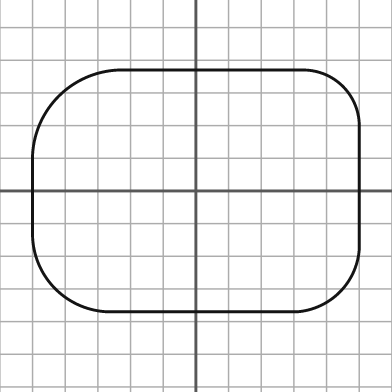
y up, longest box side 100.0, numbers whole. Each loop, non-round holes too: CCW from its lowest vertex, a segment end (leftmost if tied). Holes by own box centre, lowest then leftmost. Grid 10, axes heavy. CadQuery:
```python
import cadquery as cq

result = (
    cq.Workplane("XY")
    .moveTo(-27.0, -37.0)
    .lineTo(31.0, -37.0)
    .threePointArc((44.0, -31.0), (50.0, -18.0))
    .lineTo(50.0, 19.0)
    .threePointArc((45.0, 32.0), (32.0, 37.0))
    .lineTo(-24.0, 37.0)
    .threePointArc((-42.0, 29.0), (-50.0, 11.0))
    .lineTo(-50.0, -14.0)
    .threePointArc((-43.0, -30.0), (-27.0, -37.0))
    .close()
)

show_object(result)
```